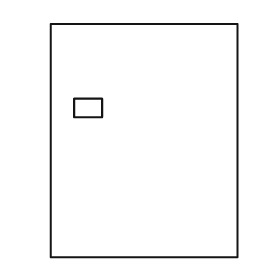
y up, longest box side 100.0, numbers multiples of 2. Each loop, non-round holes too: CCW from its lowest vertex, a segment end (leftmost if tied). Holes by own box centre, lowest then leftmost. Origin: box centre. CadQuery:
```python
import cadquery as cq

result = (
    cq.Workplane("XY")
    .moveTo(-40.0, -50.0)
    .lineTo(40.0, -50.0)
    .lineTo(40.0, 50.0)
    .lineTo(-40.0, 50.0)
    .close()
    .moveTo(-30.0, 10.0)
    .lineTo(-18.0, 10.0)
    .lineTo(-18.0, 18.0)
    .lineTo(-30.0, 18.0)
    .close()
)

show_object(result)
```